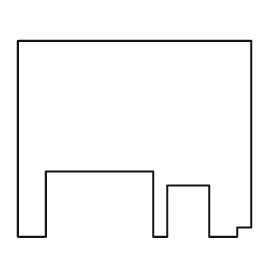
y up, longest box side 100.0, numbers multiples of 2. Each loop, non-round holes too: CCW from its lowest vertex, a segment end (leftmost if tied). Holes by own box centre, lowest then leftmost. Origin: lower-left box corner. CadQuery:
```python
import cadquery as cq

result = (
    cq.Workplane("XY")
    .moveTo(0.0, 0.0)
    .lineTo(12.0, 0.0)
    .lineTo(12.0, 28.0)
    .lineTo(58.0, 28.0)
    .lineTo(58.0, 0.0)
    .lineTo(64.0, 0.0)
    .lineTo(64.0, 22.0)
    .lineTo(82.0, 22.0)
    .lineTo(82.0, 0.0)
    .lineTo(94.0, 0.0)
    .lineTo(94.0, 4.0)
    .lineTo(100.0, 4.0)
    .lineTo(100.0, 84.0)
    .lineTo(0.0, 84.0)
    .close()
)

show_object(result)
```